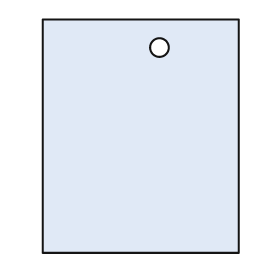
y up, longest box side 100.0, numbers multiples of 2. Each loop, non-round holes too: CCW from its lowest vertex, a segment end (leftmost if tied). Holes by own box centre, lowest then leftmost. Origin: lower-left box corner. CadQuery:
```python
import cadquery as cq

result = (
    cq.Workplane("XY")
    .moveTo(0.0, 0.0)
    .lineTo(84.0, 0.0)
    .lineTo(84.0, 100.0)
    .lineTo(0.0, 100.0)
    .close()
    .moveTo(50.0, 88.0)
    .circle(4.0)
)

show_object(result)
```